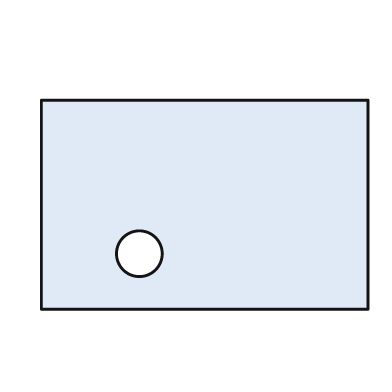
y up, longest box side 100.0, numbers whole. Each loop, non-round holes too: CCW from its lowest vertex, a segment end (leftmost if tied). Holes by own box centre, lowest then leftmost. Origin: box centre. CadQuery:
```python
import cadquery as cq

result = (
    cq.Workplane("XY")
    .moveTo(-50.0, -32.0)
    .lineTo(50.0, -32.0)
    .lineTo(50.0, 32.0)
    .lineTo(-50.0, 32.0)
    .close()
    .moveTo(-20.0, -15.0)
    .circle(7.0)
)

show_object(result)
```